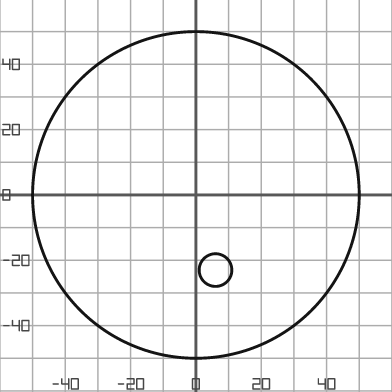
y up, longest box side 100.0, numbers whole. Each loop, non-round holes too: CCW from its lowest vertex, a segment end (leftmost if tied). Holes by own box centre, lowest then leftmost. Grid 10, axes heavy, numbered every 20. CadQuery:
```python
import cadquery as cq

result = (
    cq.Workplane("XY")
    .moveTo(0.0, 0.0)
    .circle(50.0)
    .moveTo(6.0, -23.0)
    .circle(5.0)
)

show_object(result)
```